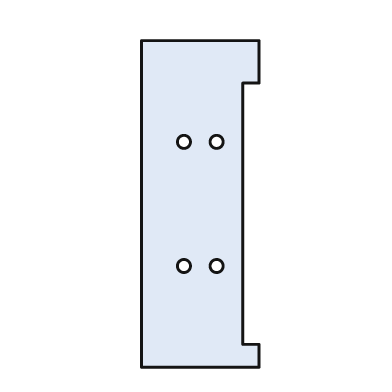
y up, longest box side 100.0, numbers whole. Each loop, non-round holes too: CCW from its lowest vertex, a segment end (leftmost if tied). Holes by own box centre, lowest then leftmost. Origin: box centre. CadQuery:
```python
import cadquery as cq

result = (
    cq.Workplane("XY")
    .moveTo(-18.0, -50.0)
    .lineTo(18.0, -50.0)
    .lineTo(18.0, -43.0)
    .lineTo(13.0, -43.0)
    .lineTo(13.0, 37.0)
    .lineTo(18.0, 37.0)
    .lineTo(18.0, 50.0)
    .lineTo(-18.0, 50.0)
    .close()
    .moveTo(-5.0, -19.0)
    .circle(2.0)
    .moveTo(5.0, -19.0)
    .circle(2.0)
    .moveTo(-5.0, 19.0)
    .circle(2.0)
    .moveTo(5.0, 19.0)
    .circle(2.0)
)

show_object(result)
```